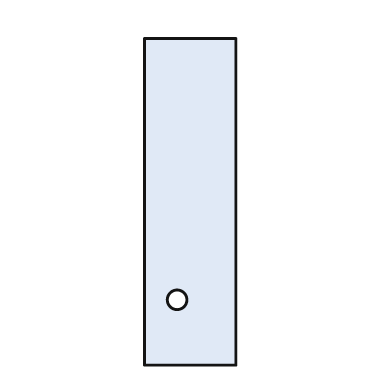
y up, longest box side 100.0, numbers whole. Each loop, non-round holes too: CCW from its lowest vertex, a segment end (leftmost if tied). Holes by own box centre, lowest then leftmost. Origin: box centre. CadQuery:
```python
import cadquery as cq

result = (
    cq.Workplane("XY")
    .moveTo(-14.0, -50.0)
    .lineTo(14.0, -50.0)
    .lineTo(14.0, 50.0)
    .lineTo(-14.0, 50.0)
    .close()
    .moveTo(-4.0, -30.0)
    .circle(3.0)
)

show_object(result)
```